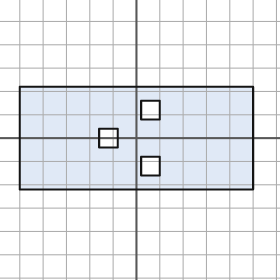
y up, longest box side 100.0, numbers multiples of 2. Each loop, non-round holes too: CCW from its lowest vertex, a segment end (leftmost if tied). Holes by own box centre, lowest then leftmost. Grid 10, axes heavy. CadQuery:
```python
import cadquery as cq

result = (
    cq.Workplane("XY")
    .moveTo(-50.0, -22.0)
    .lineTo(50.0, -22.0)
    .lineTo(50.0, 22.0)
    .lineTo(-50.0, 22.0)
    .close()
    .moveTo(2.0, -16.0)
    .lineTo(10.0, -16.0)
    .lineTo(10.0, -8.0)
    .lineTo(2.0, -8.0)
    .close()
    .moveTo(-16.0, -4.0)
    .lineTo(-8.0, -4.0)
    .lineTo(-8.0, 4.0)
    .lineTo(-16.0, 4.0)
    .close()
    .moveTo(2.0, 8.0)
    .lineTo(10.0, 8.0)
    .lineTo(10.0, 16.0)
    .lineTo(2.0, 16.0)
    .close()
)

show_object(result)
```